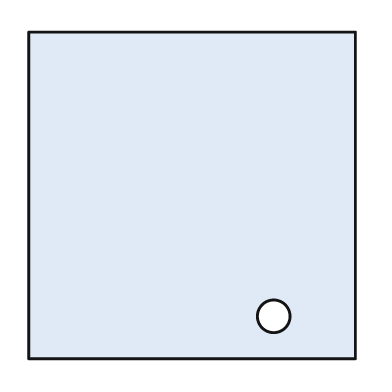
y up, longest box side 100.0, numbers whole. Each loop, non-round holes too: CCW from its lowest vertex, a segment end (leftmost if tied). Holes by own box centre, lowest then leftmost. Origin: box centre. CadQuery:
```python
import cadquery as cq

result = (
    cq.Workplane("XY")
    .moveTo(-50.0, -50.0)
    .lineTo(50.0, -50.0)
    .lineTo(50.0, 50.0)
    .lineTo(-50.0, 50.0)
    .close()
    .moveTo(25.0, -37.0)
    .circle(5.0)
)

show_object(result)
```